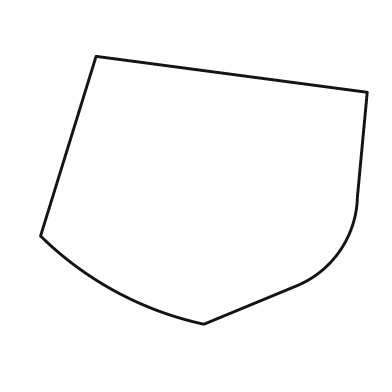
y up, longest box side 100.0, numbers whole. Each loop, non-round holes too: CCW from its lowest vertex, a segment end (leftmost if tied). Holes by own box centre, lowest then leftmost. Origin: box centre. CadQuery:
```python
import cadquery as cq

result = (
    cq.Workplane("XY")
    .moveTo(0.0, -41.0)
    .lineTo(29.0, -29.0)
    .threePointArc((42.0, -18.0), (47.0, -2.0))
    .lineTo(50.0, 30.0)
    .lineTo(-33.0, 41.0)
    .lineTo(-50.0, -14.0)
    .threePointArc((-27.0, -31.0), (0.0, -41.0))
    .close()
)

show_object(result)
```